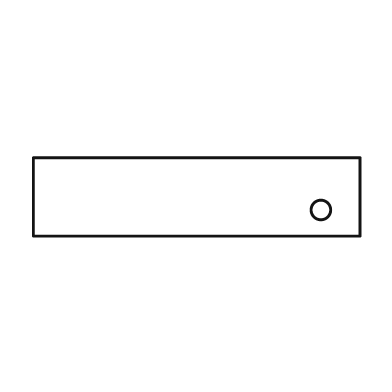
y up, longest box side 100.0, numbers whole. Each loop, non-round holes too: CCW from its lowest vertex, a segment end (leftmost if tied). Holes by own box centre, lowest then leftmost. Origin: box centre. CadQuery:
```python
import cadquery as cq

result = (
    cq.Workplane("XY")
    .moveTo(-50.0, -12.0)
    .lineTo(50.0, -12.0)
    .lineTo(50.0, 12.0)
    .lineTo(-50.0, 12.0)
    .close()
    .moveTo(38.0, -4.0)
    .circle(3.0)
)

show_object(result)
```